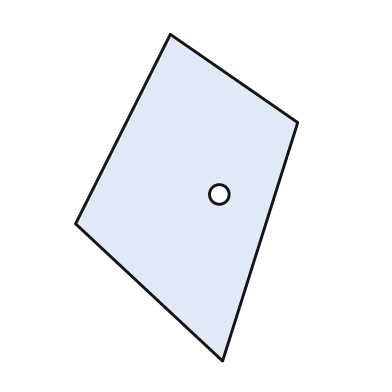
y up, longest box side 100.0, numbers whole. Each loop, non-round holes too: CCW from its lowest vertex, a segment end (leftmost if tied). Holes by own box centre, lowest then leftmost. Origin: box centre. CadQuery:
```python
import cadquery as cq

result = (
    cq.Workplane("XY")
    .moveTo(11.0, -50.0)
    .lineTo(34.0, 23.0)
    .lineTo(-5.0, 50.0)
    .lineTo(-34.0, -8.0)
    .close()
    .moveTo(10.0, 1.0)
    .circle(3.0)
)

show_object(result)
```